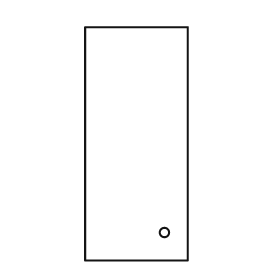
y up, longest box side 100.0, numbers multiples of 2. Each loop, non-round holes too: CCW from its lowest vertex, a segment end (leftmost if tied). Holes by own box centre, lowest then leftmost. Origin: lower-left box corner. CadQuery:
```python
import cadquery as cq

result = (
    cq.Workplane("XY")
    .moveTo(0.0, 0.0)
    .lineTo(44.0, 0.0)
    .lineTo(44.0, 100.0)
    .lineTo(0.0, 100.0)
    .close()
    .moveTo(34.0, 12.0)
    .circle(2.0)
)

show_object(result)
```